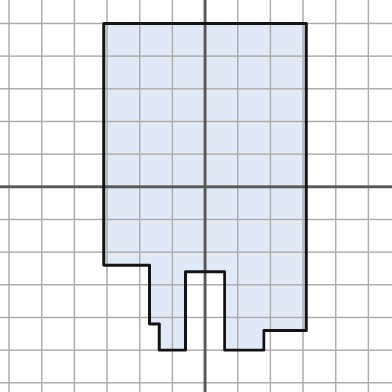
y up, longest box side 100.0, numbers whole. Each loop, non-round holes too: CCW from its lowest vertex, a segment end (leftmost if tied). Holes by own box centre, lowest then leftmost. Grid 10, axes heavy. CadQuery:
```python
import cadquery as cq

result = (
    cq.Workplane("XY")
    .moveTo(-14.0, -50.0)
    .lineTo(-6.0, -50.0)
    .lineTo(-6.0, -26.0)
    .lineTo(6.0, -26.0)
    .lineTo(6.0, -50.0)
    .lineTo(18.0, -50.0)
    .lineTo(18.0, -44.0)
    .lineTo(31.0, -44.0)
    .lineTo(31.0, 50.0)
    .lineTo(-31.0, 50.0)
    .lineTo(-31.0, -24.0)
    .lineTo(-17.0, -24.0)
    .lineTo(-17.0, -42.0)
    .lineTo(-14.0, -42.0)
    .close()
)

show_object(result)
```